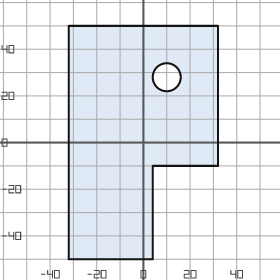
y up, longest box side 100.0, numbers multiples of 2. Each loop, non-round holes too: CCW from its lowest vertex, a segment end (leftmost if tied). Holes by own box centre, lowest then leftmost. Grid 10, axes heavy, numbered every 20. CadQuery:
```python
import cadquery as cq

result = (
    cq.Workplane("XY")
    .moveTo(-32.0, -50.0)
    .lineTo(4.0, -50.0)
    .lineTo(4.0, -10.0)
    .lineTo(32.0, -10.0)
    .lineTo(32.0, 50.0)
    .lineTo(-32.0, 50.0)
    .close()
    .moveTo(10.0, 28.0)
    .circle(6.0)
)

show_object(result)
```